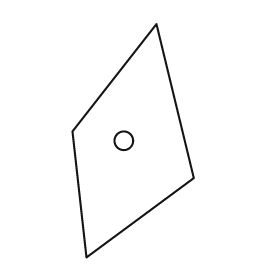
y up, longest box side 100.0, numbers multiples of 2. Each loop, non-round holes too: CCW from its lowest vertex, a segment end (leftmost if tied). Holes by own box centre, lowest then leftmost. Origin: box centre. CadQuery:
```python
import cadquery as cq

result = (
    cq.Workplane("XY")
    .moveTo(-20.0, -50.0)
    .lineTo(26.0, -16.0)
    .lineTo(10.0, 50.0)
    .lineTo(-26.0, 4.0)
    .close()
    .moveTo(-4.0, 0.0)
    .circle(4.0)
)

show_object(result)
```